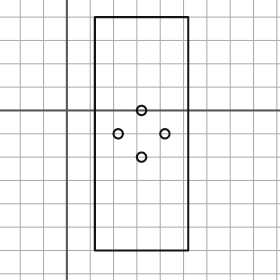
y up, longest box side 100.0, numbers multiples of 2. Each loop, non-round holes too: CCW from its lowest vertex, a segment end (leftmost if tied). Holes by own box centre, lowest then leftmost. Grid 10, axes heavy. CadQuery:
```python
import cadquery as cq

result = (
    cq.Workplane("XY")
    .moveTo(12.0, -60.0)
    .lineTo(52.0, -60.0)
    .lineTo(52.0, 40.0)
    .lineTo(12.0, 40.0)
    .close()
    .moveTo(32.0, -20.0)
    .circle(2.0)
    .moveTo(22.0, -10.0)
    .circle(2.0)
    .moveTo(42.0, -10.0)
    .circle(2.0)
    .moveTo(32.0, 0.0)
    .circle(2.0)
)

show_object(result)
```